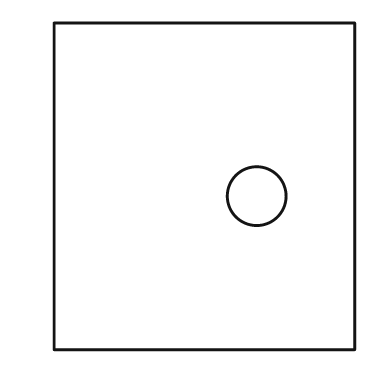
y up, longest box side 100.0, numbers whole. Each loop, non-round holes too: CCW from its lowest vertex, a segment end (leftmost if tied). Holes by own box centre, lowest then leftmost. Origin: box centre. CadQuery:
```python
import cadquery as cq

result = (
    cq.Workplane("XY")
    .moveTo(-46.0, -50.0)
    .lineTo(46.0, -50.0)
    .lineTo(46.0, 50.0)
    .lineTo(-46.0, 50.0)
    .close()
    .moveTo(16.0, -3.0)
    .circle(9.0)
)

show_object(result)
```